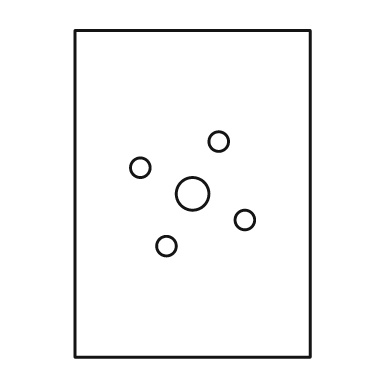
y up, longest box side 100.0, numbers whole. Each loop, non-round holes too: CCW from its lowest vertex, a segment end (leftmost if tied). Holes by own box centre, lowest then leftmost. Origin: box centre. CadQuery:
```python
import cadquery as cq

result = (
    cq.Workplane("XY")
    .moveTo(-36.0, -50.0)
    .lineTo(36.0, -50.0)
    .lineTo(36.0, 50.0)
    .lineTo(-36.0, 50.0)
    .close()
    .moveTo(-8.0, -16.0)
    .circle(3.0)
    .moveTo(16.0, -8.0)
    .circle(3.0)
    .moveTo(0.0, 0.0)
    .circle(5.0)
    .moveTo(-16.0, 8.0)
    .circle(3.0)
    .moveTo(8.0, 16.0)
    .circle(3.0)
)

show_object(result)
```